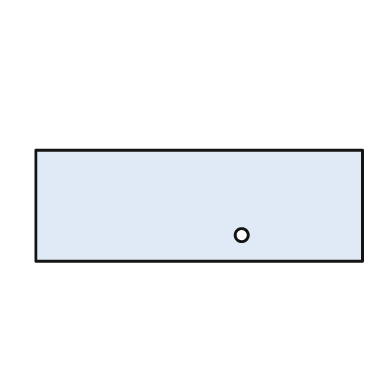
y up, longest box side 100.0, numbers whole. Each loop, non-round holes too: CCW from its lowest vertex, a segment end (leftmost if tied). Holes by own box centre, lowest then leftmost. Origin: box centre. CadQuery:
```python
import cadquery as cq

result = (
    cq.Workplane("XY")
    .moveTo(-50.0, -17.0)
    .lineTo(50.0, -17.0)
    .lineTo(50.0, 17.0)
    .lineTo(-50.0, 17.0)
    .close()
    .moveTo(13.0, -9.0)
    .circle(2.0)
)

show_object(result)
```